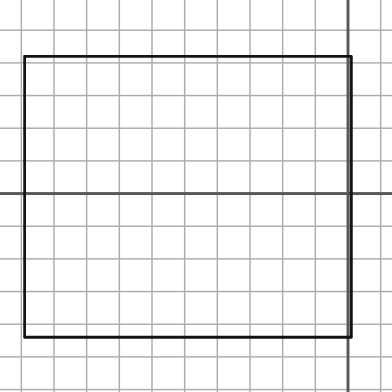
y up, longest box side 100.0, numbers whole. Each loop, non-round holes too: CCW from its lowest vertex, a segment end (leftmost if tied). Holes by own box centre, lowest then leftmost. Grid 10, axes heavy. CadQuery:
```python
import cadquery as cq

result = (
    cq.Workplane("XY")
    .moveTo(-99.0, -44.0)
    .lineTo(1.0, -44.0)
    .lineTo(1.0, 42.0)
    .lineTo(-99.0, 42.0)
    .close()
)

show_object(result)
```